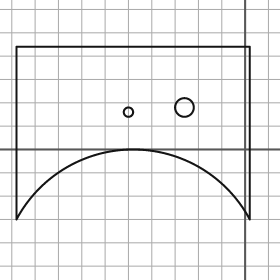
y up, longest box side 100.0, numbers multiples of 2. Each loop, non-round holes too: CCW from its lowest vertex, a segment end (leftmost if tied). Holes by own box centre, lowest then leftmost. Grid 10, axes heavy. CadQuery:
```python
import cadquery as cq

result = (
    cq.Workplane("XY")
    .moveTo(-98.0, -30.0)
    .threePointArc((-48.0, 0.0), (2.0, -30.0))
    .lineTo(2.0, 44.0)
    .lineTo(-98.0, 44.0)
    .close()
    .moveTo(-50.0, 16.0)
    .circle(2.0)
    .moveTo(-26.0, 18.0)
    .circle(4.0)
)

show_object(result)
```